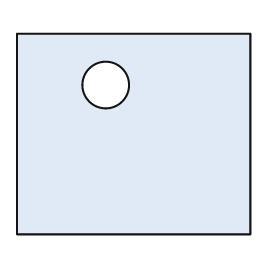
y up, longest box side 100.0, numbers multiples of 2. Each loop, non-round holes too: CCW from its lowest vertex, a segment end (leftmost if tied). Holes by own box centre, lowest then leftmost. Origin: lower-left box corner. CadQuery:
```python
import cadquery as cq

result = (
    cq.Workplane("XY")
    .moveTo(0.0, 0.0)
    .lineTo(100.0, 0.0)
    .lineTo(100.0, 86.0)
    .lineTo(0.0, 86.0)
    .close()
    .moveTo(38.0, 64.0)
    .circle(10.0)
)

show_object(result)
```